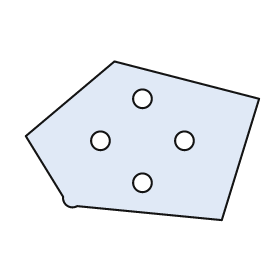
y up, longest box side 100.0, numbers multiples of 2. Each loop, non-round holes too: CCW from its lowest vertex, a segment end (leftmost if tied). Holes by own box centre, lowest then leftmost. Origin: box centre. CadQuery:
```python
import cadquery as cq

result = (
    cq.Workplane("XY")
    .moveTo(34.0, -34.0)
    .lineTo(50.0, 18.0)
    .lineTo(-12.0, 34.0)
    .lineTo(-50.0, 2.0)
    .lineTo(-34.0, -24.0)
    .threePointArc((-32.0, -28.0), (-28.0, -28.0))
    .close()
    .moveTo(0.0, -18.0)
    .circle(4.0)
    .moveTo(-18.0, 0.0)
    .circle(4.0)
    .moveTo(18.0, 0.0)
    .circle(4.0)
    .moveTo(0.0, 18.0)
    .circle(4.0)
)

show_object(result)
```